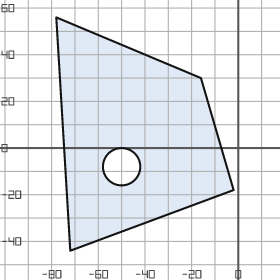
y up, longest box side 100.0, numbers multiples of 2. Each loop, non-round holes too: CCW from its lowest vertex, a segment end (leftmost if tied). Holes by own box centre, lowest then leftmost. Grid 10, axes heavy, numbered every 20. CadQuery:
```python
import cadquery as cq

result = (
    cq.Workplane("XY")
    .moveTo(-72.0, -44.0)
    .lineTo(-2.0, -18.0)
    .lineTo(-16.0, 30.0)
    .lineTo(-78.0, 56.0)
    .close()
    .moveTo(-50.0, -8.0)
    .circle(8.0)
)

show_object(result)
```